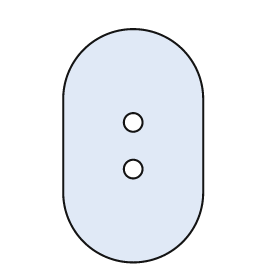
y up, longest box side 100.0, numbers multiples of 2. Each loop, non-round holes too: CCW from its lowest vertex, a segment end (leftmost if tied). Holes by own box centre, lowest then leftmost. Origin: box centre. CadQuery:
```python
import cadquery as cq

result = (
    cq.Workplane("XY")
    .moveTo(-30.0, -20.0)
    .threePointArc((0.0, -50.0), (30.0, -20.0))
    .lineTo(30.0, 20.0)
    .threePointArc((0.0, 50.0), (-30.0, 20.0))
    .close()
    .moveTo(0.0, -10.0)
    .circle(4.0)
    .moveTo(0.0, 10.0)
    .circle(4.0)
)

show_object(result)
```